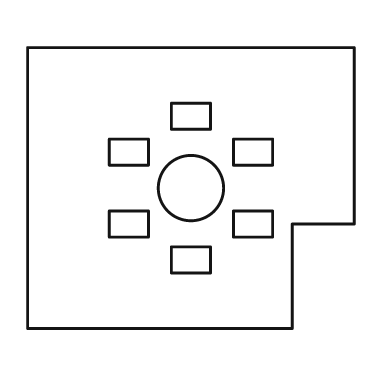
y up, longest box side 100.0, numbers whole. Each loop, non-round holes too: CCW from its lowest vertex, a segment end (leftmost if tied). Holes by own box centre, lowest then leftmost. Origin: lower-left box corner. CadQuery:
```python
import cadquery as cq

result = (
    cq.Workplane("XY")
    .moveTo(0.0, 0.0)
    .lineTo(81.0, 0.0)
    .lineTo(81.0, 32.0)
    .lineTo(100.0, 32.0)
    .lineTo(100.0, 86.0)
    .lineTo(0.0, 86.0)
    .close()
    .moveTo(44.0, 17.0)
    .lineTo(56.0, 17.0)
    .lineTo(56.0, 25.0)
    .lineTo(44.0, 25.0)
    .close()
    .moveTo(25.0, 28.0)
    .lineTo(37.0, 28.0)
    .lineTo(37.0, 36.0)
    .lineTo(25.0, 36.0)
    .close()
    .moveTo(63.0, 28.0)
    .lineTo(75.0, 28.0)
    .lineTo(75.0, 36.0)
    .lineTo(63.0, 36.0)
    .close()
    .moveTo(50.0, 43.0)
    .circle(10.0)
    .moveTo(25.0, 50.0)
    .lineTo(37.0, 50.0)
    .lineTo(37.0, 58.0)
    .lineTo(25.0, 58.0)
    .close()
    .moveTo(63.0, 50.0)
    .lineTo(75.0, 50.0)
    .lineTo(75.0, 58.0)
    .lineTo(63.0, 58.0)
    .close()
    .moveTo(44.0, 61.0)
    .lineTo(56.0, 61.0)
    .lineTo(56.0, 69.0)
    .lineTo(44.0, 69.0)
    .close()
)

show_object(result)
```